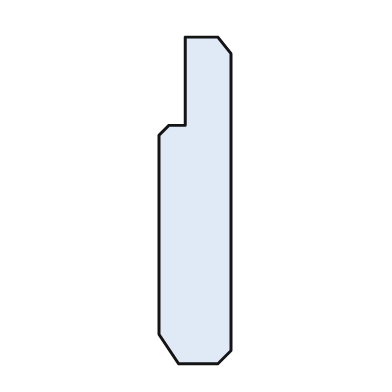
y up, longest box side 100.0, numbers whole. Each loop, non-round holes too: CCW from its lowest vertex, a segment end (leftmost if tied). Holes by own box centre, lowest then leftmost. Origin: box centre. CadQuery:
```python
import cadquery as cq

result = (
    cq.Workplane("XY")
    .moveTo(-5.0, -50.0)
    .lineTo(7.0, -50.0)
    .lineTo(11.0, -46.0)
    .lineTo(11.0, 45.0)
    .lineTo(7.0, 50.0)
    .lineTo(-3.0, 50.0)
    .lineTo(-3.0, 23.0)
    .lineTo(-8.0, 23.0)
    .lineTo(-11.0, 20.0)
    .lineTo(-11.0, -41.0)
    .close()
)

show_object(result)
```